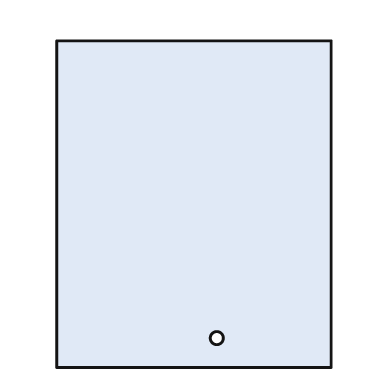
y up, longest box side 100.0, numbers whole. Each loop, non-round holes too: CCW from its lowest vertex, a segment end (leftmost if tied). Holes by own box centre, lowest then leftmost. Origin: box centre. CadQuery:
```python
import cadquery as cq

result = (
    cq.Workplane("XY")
    .moveTo(-42.0, -50.0)
    .lineTo(42.0, -50.0)
    .lineTo(42.0, 50.0)
    .lineTo(-42.0, 50.0)
    .close()
    .moveTo(7.0, -41.0)
    .circle(2.0)
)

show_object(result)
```